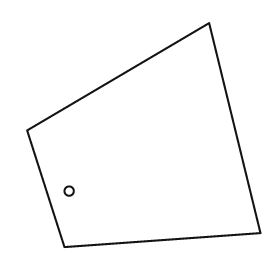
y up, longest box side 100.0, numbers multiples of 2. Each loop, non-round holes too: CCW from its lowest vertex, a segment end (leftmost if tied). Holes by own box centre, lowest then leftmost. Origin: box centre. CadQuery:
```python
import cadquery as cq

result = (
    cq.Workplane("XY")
    .moveTo(-34.0, -48.0)
    .lineTo(50.0, -42.0)
    .lineTo(28.0, 48.0)
    .lineTo(-50.0, 2.0)
    .close()
    .moveTo(-32.0, -24.0)
    .circle(2.0)
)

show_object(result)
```